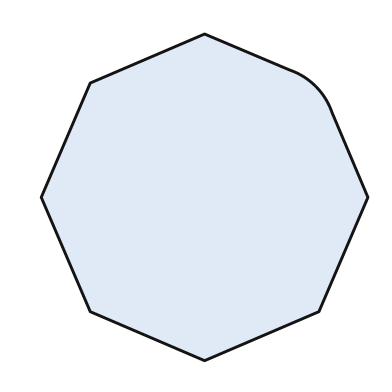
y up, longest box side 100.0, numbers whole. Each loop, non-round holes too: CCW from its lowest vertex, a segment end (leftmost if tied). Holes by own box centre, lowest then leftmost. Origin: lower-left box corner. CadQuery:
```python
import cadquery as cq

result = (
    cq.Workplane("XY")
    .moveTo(50.0, 0.0)
    .lineTo(85.0, 15.0)
    .lineTo(100.0, 50.0)
    .lineTo(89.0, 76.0)
    .threePointArc((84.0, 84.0), (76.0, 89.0))
    .lineTo(50.0, 100.0)
    .lineTo(15.0, 85.0)
    .lineTo(0.0, 50.0)
    .lineTo(15.0, 15.0)
    .close()
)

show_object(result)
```